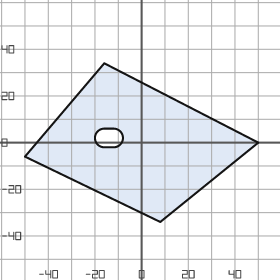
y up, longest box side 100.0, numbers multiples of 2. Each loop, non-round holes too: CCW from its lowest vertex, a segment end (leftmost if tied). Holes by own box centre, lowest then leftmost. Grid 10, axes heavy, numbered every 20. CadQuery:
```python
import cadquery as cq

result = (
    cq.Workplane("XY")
    .moveTo(8.0, -34.0)
    .lineTo(50.0, 0.0)
    .lineTo(-16.0, 34.0)
    .lineTo(-50.0, -6.0)
    .close()
    .moveTo(-16.0, -2.0)
    .lineTo(-12.0, -2.0)
    .threePointArc((-8.0, 2.0), (-12.0, 6.0))
    .lineTo(-16.0, 6.0)
    .threePointArc((-20.0, 2.0), (-16.0, -2.0))
    .close()
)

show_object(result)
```